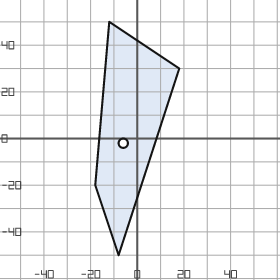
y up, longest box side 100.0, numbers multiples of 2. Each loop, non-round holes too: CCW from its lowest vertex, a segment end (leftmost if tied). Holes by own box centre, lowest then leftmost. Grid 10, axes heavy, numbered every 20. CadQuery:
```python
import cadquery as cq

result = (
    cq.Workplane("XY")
    .moveTo(-8.0, -50.0)
    .lineTo(18.0, 30.0)
    .lineTo(-12.0, 50.0)
    .lineTo(-18.0, -20.0)
    .close()
    .moveTo(-6.0, -2.0)
    .circle(2.0)
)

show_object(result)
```